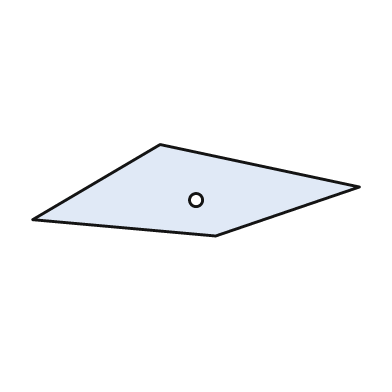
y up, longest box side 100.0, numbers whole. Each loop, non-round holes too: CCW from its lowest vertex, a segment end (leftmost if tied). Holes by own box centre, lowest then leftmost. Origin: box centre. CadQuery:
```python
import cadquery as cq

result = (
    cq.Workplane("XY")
    .moveTo(6.0, -14.0)
    .lineTo(50.0, 1.0)
    .lineTo(-11.0, 14.0)
    .lineTo(-50.0, -9.0)
    .close()
    .moveTo(0.0, -3.0)
    .circle(2.0)
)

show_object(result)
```